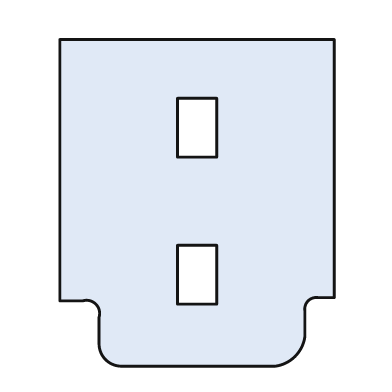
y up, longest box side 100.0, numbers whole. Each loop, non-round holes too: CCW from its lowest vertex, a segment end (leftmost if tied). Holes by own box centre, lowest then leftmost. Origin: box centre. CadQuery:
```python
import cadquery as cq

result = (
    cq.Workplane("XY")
    .moveTo(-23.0, -50.0)
    .lineTo(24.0, -50.0)
    .threePointArc((30.0, -47.0), (33.0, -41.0))
    .lineTo(33.0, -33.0)
    .threePointArc((34.0, -30.0), (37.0, -29.0))
    .lineTo(42.0, -29.0)
    .lineTo(42.0, 50.0)
    .lineTo(-42.0, 50.0)
    .lineTo(-42.0, -30.0)
    .lineTo(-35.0, -30.0)
    .threePointArc((-31.0, -31.0), (-30.0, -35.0))
    .lineTo(-30.0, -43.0)
    .threePointArc((-28.0, -48.0), (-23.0, -50.0))
    .close()
    .moveTo(-6.0, -31.0)
    .lineTo(6.0, -31.0)
    .lineTo(6.0, -13.0)
    .lineTo(-6.0, -13.0)
    .close()
    .moveTo(-6.0, 14.0)
    .lineTo(6.0, 14.0)
    .lineTo(6.0, 32.0)
    .lineTo(-6.0, 32.0)
    .close()
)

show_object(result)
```